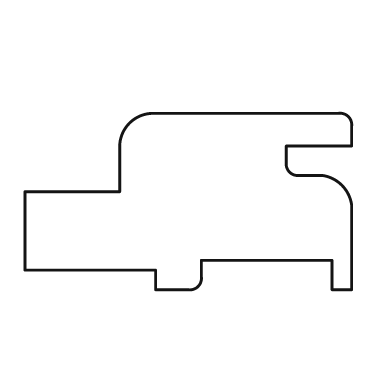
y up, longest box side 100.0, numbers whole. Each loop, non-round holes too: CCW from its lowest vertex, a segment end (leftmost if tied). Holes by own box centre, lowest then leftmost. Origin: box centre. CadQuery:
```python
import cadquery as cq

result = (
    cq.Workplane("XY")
    .moveTo(-10.0, -27.0)
    .lineTo(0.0, -27.0)
    .threePointArc((3.0, -26.0), (4.0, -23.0))
    .lineTo(4.0, -18.0)
    .lineTo(44.0, -18.0)
    .lineTo(44.0, -27.0)
    .lineTo(50.0, -27.0)
    .lineTo(50.0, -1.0)
    .threePointArc((47.0, 5.0), (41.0, 8.0))
    .lineTo(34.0, 8.0)
    .threePointArc((31.0, 9.0), (30.0, 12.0))
    .lineTo(30.0, 17.0)
    .lineTo(50.0, 17.0)
    .lineTo(50.0, 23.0)
    .threePointArc((49.0, 26.0), (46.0, 27.0))
    .lineTo(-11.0, 27.0)
    .threePointArc((-18.0, 24.0), (-21.0, 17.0))
    .lineTo(-21.0, 3.0)
    .lineTo(-50.0, 3.0)
    .lineTo(-50.0, -21.0)
    .lineTo(-10.0, -21.0)
    .close()
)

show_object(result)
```